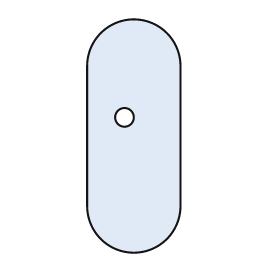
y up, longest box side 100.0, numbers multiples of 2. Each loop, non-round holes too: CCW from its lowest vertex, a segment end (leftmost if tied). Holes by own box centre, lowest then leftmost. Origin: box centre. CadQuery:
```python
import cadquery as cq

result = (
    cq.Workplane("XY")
    .moveTo(-20.0, -30.0)
    .threePointArc((0.0, -50.0), (20.0, -30.0))
    .lineTo(20.0, 30.0)
    .threePointArc((0.0, 50.0), (-20.0, 30.0))
    .close()
    .moveTo(-4.0, 8.0)
    .circle(4.0)
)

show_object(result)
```